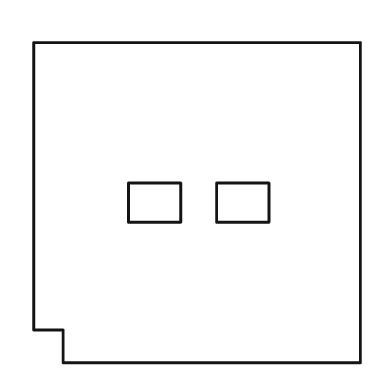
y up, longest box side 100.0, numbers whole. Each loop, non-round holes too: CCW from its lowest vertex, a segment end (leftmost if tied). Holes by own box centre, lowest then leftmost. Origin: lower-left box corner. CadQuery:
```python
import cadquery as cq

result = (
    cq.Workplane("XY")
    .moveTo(9.0, 0.0)
    .lineTo(100.0, 0.0)
    .lineTo(100.0, 98.0)
    .lineTo(0.0, 98.0)
    .lineTo(0.0, 10.0)
    .lineTo(9.0, 10.0)
    .close()
    .moveTo(29.0, 43.0)
    .lineTo(45.0, 43.0)
    .lineTo(45.0, 55.0)
    .lineTo(29.0, 55.0)
    .close()
    .moveTo(56.0, 43.0)
    .lineTo(72.0, 43.0)
    .lineTo(72.0, 55.0)
    .lineTo(56.0, 55.0)
    .close()
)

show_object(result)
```